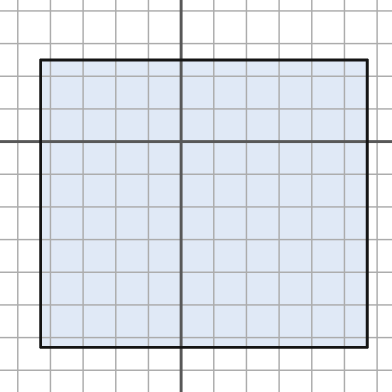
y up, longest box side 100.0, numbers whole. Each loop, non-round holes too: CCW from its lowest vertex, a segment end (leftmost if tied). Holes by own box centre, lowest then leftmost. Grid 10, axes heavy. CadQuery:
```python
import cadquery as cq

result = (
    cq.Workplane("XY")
    .moveTo(-43.0, -63.0)
    .lineTo(57.0, -63.0)
    .lineTo(57.0, 25.0)
    .lineTo(-43.0, 25.0)
    .close()
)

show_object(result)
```